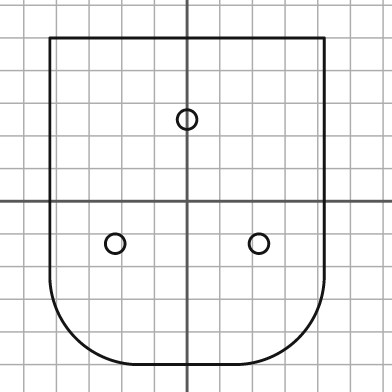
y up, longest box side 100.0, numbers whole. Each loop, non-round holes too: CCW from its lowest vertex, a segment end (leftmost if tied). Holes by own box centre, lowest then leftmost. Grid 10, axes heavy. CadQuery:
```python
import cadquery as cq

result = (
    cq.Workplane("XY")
    .moveTo(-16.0, -50.0)
    .lineTo(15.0, -50.0)
    .threePointArc((34.0, -42.0), (42.0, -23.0))
    .lineTo(42.0, 50.0)
    .lineTo(-42.0, 50.0)
    .lineTo(-42.0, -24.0)
    .threePointArc((-34.0, -42.0), (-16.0, -50.0))
    .close()
    .moveTo(-22.0, -13.0)
    .circle(3.0)
    .moveTo(22.0, -13.0)
    .circle(3.0)
    .moveTo(0.0, 25.0)
    .circle(3.0)
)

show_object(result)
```